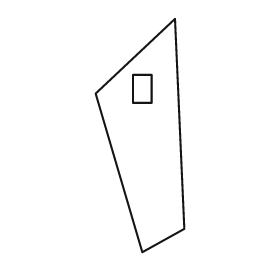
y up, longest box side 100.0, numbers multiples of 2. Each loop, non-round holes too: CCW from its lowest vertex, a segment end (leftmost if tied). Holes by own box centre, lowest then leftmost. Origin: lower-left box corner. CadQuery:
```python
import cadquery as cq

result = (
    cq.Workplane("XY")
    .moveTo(20.0, 0.0)
    .lineTo(38.0, 10.0)
    .lineTo(34.0, 100.0)
    .lineTo(0.0, 68.0)
    .close()
    .moveTo(16.0, 64.0)
    .lineTo(24.0, 64.0)
    .lineTo(24.0, 76.0)
    .lineTo(16.0, 76.0)
    .close()
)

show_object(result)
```